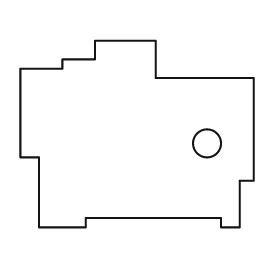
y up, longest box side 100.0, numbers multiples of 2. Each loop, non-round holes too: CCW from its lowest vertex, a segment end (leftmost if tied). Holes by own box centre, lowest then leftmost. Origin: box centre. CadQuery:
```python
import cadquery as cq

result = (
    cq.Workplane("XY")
    .moveTo(-42.0, -40.0)
    .lineTo(-22.0, -40.0)
    .lineTo(-22.0, -36.0)
    .lineTo(36.0, -36.0)
    .lineTo(36.0, -40.0)
    .lineTo(44.0, -40.0)
    .lineTo(44.0, -20.0)
    .lineTo(50.0, -20.0)
    .lineTo(50.0, 24.0)
    .lineTo(8.0, 24.0)
    .lineTo(8.0, 40.0)
    .lineTo(-18.0, 40.0)
    .lineTo(-18.0, 32.0)
    .lineTo(-32.0, 32.0)
    .lineTo(-32.0, 28.0)
    .lineTo(-50.0, 28.0)
    .lineTo(-50.0, -10.0)
    .lineTo(-42.0, -10.0)
    .close()
    .moveTo(30.0, -4.0)
    .circle(6.0)
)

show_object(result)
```